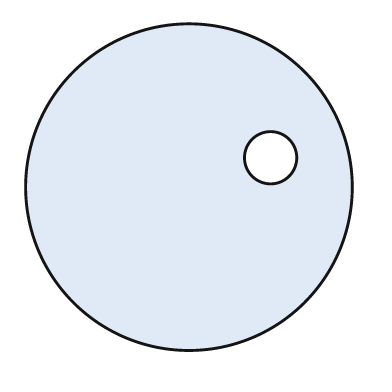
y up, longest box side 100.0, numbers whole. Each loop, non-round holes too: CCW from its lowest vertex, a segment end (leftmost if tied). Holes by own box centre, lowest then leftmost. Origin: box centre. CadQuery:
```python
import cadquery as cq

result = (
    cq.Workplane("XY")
    .moveTo(0.0, 0.0)
    .circle(50.0)
    .moveTo(25.0, 9.0)
    .circle(8.0)
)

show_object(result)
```